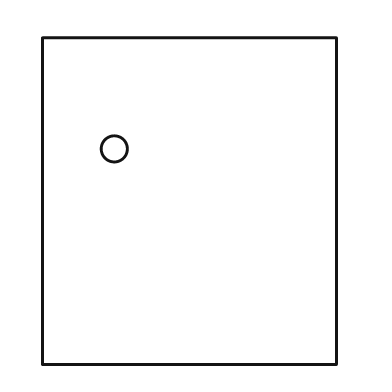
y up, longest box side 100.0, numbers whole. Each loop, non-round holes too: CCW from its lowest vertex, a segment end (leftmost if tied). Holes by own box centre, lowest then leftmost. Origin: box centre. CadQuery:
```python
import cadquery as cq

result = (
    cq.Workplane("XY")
    .moveTo(-45.0, -50.0)
    .lineTo(45.0, -50.0)
    .lineTo(45.0, 50.0)
    .lineTo(-45.0, 50.0)
    .close()
    .moveTo(-23.0, 16.0)
    .circle(4.0)
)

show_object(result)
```